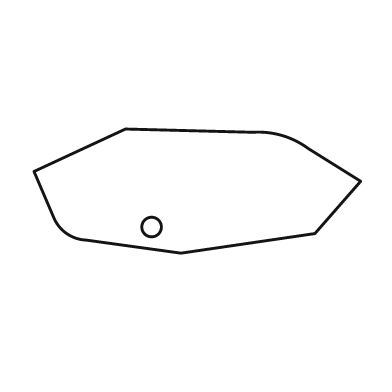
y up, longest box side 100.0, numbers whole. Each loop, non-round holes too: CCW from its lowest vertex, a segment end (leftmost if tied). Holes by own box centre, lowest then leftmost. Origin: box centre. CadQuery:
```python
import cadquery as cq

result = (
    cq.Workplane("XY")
    .moveTo(-5.0, -19.0)
    .lineTo(36.0, -13.0)
    .lineTo(50.0, 3.0)
    .lineTo(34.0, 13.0)
    .threePointArc((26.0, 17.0), (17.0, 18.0))
    .lineTo(-22.0, 19.0)
    .lineTo(-50.0, 6.0)
    .lineTo(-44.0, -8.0)
    .threePointArc((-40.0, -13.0), (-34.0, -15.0))
    .close()
    .moveTo(-14.0, -11.0)
    .circle(3.0)
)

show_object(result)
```